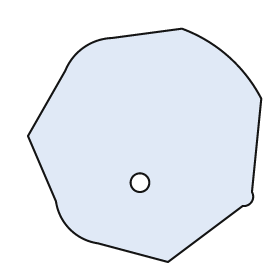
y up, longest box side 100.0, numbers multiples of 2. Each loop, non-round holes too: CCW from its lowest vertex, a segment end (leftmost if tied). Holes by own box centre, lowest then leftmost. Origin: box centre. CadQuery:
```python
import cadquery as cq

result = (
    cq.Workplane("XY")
    .moveTo(10.0, -50.0)
    .lineTo(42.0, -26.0)
    .threePointArc((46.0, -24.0), (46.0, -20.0))
    .lineTo(50.0, 20.0)
    .threePointArc((36.0, 38.0), (16.0, 50.0))
    .lineTo(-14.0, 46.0)
    .threePointArc((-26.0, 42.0), (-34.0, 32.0))
    .lineTo(-50.0, 4.0)
    .lineTo(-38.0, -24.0)
    .threePointArc((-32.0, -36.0), (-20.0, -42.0))
    .close()
    .moveTo(-2.0, -16.0)
    .circle(4.0)
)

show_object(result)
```